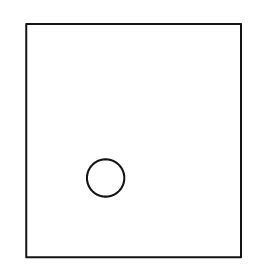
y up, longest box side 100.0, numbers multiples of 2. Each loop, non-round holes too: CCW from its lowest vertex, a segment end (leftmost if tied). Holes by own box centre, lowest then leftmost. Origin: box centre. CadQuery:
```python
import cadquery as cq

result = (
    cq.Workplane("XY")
    .moveTo(-46.0, -50.0)
    .lineTo(46.0, -50.0)
    .lineTo(46.0, 50.0)
    .lineTo(-46.0, 50.0)
    .close()
    .moveTo(-12.0, -16.0)
    .circle(8.0)
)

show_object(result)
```